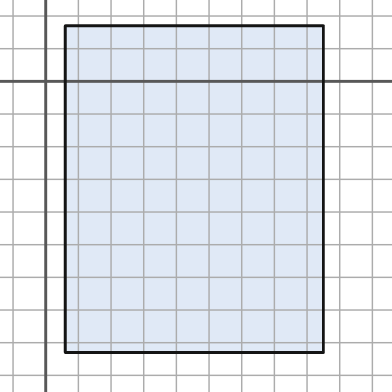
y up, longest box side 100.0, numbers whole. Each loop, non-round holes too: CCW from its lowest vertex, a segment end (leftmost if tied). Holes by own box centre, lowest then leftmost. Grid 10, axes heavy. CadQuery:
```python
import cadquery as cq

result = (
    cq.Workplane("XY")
    .moveTo(6.0, -83.0)
    .lineTo(85.0, -83.0)
    .lineTo(85.0, 17.0)
    .lineTo(6.0, 17.0)
    .close()
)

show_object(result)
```